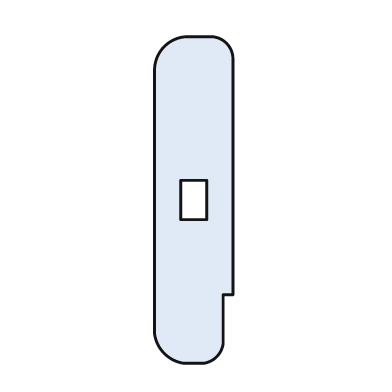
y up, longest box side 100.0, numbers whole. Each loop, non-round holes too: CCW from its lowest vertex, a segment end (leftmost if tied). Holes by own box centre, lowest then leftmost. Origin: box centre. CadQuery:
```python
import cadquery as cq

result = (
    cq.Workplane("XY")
    .moveTo(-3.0, -50.0)
    .lineTo(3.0, -50.0)
    .threePointArc((7.0, -48.0), (9.0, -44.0))
    .lineTo(9.0, -29.0)
    .lineTo(12.0, -29.0)
    .lineTo(12.0, 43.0)
    .threePointArc((10.0, 48.0), (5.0, 50.0))
    .lineTo(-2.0, 50.0)
    .threePointArc((-9.0, 47.0), (-12.0, 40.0))
    .lineTo(-12.0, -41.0)
    .threePointArc((-9.0, -47.0), (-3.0, -50.0))
    .close()
    .moveTo(-4.0, -6.0)
    .lineTo(4.0, -6.0)
    .lineTo(4.0, 6.0)
    .lineTo(-4.0, 6.0)
    .close()
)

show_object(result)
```